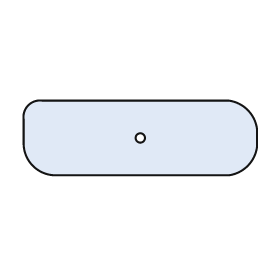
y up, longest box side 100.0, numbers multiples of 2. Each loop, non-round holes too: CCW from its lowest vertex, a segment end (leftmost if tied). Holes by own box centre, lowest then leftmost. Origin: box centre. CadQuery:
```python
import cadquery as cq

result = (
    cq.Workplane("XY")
    .moveTo(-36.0, -16.0)
    .lineTo(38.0, -16.0)
    .threePointArc((46.0, -12.0), (50.0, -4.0))
    .lineTo(50.0, 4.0)
    .threePointArc((46.0, 12.0), (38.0, 16.0))
    .lineTo(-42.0, 16.0)
    .threePointArc((-48.0, 14.0), (-50.0, 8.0))
    .lineTo(-50.0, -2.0)
    .threePointArc((-46.0, -12.0), (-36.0, -16.0))
    .close()
    .moveTo(0.0, 0.0)
    .circle(2.0)
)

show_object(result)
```